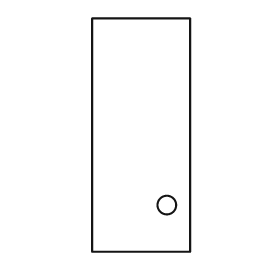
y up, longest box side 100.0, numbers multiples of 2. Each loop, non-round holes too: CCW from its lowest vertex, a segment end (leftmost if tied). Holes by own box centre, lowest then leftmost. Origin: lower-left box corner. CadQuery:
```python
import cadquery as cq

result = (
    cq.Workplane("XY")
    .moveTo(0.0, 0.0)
    .lineTo(42.0, 0.0)
    .lineTo(42.0, 100.0)
    .lineTo(0.0, 100.0)
    .close()
    .moveTo(32.0, 20.0)
    .circle(4.0)
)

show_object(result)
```